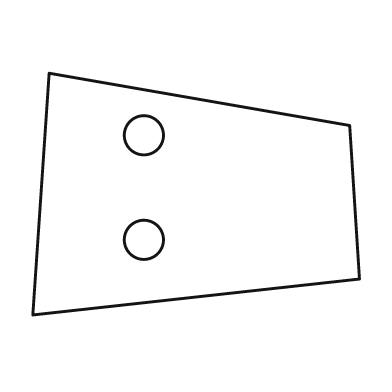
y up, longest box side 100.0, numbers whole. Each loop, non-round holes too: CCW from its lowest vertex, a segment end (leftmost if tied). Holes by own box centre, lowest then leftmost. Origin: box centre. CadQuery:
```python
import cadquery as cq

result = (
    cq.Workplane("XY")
    .moveTo(-50.0, -37.0)
    .lineTo(50.0, -26.0)
    .lineTo(47.0, 21.0)
    .lineTo(-45.0, 37.0)
    .close()
    .moveTo(-16.0, -14.0)
    .circle(6.0)
    .moveTo(-16.0, 18.0)
    .circle(6.0)
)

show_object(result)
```